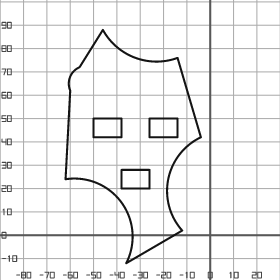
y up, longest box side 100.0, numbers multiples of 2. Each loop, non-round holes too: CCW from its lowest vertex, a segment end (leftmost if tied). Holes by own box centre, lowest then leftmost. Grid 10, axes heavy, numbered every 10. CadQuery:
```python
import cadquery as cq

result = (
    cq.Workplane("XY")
    .moveTo(-36.0, -12.0)
    .lineTo(-12.0, 2.0)
    .threePointArc((-18.0, 24.0), (-4.0, 42.0))
    .lineTo(-14.0, 76.0)
    .threePointArc((-32.0, 76.0), (-46.0, 88.0))
    .lineTo(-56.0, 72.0)
    .threePointArc((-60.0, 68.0), (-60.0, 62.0))
    .lineTo(-62.0, 24.0)
    .threePointArc((-38.0, 14.0), (-36.0, -12.0))
    .close()
    .moveTo(-38.0, 20.0)
    .lineTo(-26.0, 20.0)
    .lineTo(-26.0, 28.0)
    .lineTo(-38.0, 28.0)
    .close()
    .moveTo(-50.0, 42.0)
    .lineTo(-38.0, 42.0)
    .lineTo(-38.0, 50.0)
    .lineTo(-50.0, 50.0)
    .close()
    .moveTo(-26.0, 42.0)
    .lineTo(-14.0, 42.0)
    .lineTo(-14.0, 50.0)
    .lineTo(-26.0, 50.0)
    .close()
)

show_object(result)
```